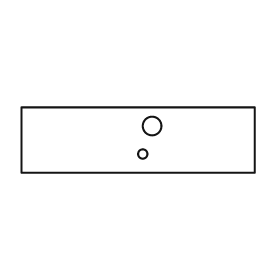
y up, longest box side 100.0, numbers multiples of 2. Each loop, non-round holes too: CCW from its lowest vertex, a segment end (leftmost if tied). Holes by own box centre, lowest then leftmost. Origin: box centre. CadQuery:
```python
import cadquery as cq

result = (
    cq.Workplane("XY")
    .moveTo(-50.0, -14.0)
    .lineTo(50.0, -14.0)
    .lineTo(50.0, 14.0)
    .lineTo(-50.0, 14.0)
    .close()
    .moveTo(2.0, -6.0)
    .circle(2.0)
    .moveTo(6.0, 6.0)
    .circle(4.0)
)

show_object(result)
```